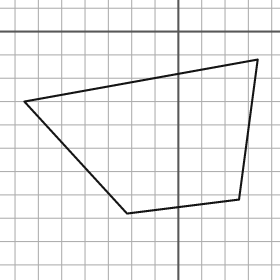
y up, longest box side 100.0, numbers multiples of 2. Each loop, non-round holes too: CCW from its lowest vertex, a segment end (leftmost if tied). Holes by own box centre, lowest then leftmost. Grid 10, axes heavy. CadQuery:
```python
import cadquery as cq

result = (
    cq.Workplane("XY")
    .moveTo(-22.0, -78.0)
    .lineTo(26.0, -72.0)
    .lineTo(34.0, -12.0)
    .lineTo(-66.0, -30.0)
    .close()
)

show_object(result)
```